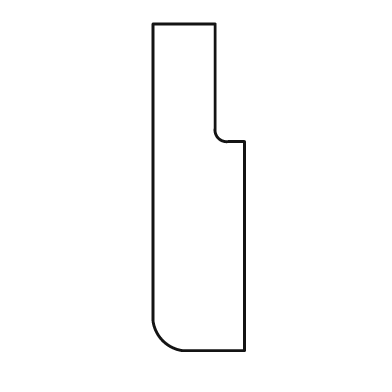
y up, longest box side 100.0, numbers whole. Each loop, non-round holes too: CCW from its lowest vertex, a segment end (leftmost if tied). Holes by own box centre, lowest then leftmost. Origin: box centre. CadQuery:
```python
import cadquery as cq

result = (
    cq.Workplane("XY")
    .moveTo(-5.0, -50.0)
    .lineTo(14.0, -50.0)
    .lineTo(14.0, 14.0)
    .lineTo(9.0, 14.0)
    .threePointArc((6.0, 15.0), (5.0, 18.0))
    .lineTo(5.0, 50.0)
    .lineTo(-14.0, 50.0)
    .lineTo(-14.0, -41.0)
    .threePointArc((-11.0, -47.0), (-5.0, -50.0))
    .close()
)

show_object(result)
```